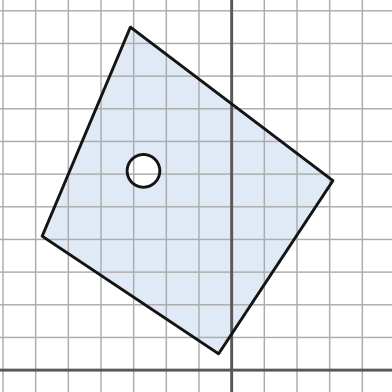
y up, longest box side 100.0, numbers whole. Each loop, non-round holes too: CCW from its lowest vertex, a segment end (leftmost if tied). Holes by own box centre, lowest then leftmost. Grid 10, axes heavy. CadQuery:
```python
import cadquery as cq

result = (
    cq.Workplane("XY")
    .moveTo(-4.0, 5.0)
    .lineTo(31.0, 58.0)
    .lineTo(-31.0, 105.0)
    .lineTo(-58.0, 41.0)
    .close()
    .moveTo(-27.0, 61.0)
    .circle(5.0)
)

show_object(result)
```